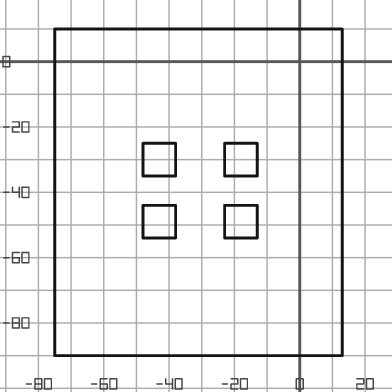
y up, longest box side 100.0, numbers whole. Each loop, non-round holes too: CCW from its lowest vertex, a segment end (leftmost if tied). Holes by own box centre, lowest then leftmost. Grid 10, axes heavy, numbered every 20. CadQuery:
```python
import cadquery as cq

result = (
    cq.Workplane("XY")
    .moveTo(-75.0, -90.0)
    .lineTo(13.0, -90.0)
    .lineTo(13.0, 10.0)
    .lineTo(-75.0, 10.0)
    .close()
    .moveTo(-48.0, -54.0)
    .lineTo(-38.0, -54.0)
    .lineTo(-38.0, -44.0)
    .lineTo(-48.0, -44.0)
    .close()
    .moveTo(-23.0, -54.0)
    .lineTo(-13.0, -54.0)
    .lineTo(-13.0, -44.0)
    .lineTo(-23.0, -44.0)
    .close()
    .moveTo(-48.0, -35.0)
    .lineTo(-38.0, -35.0)
    .lineTo(-38.0, -25.0)
    .lineTo(-48.0, -25.0)
    .close()
    .moveTo(-23.0, -35.0)
    .lineTo(-13.0, -35.0)
    .lineTo(-13.0, -25.0)
    .lineTo(-23.0, -25.0)
    .close()
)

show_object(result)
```